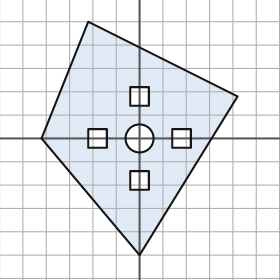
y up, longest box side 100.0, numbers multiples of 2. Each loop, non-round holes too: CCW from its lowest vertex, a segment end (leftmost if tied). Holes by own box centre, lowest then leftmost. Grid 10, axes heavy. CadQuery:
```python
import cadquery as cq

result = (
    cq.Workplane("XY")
    .moveTo(0.0, -50.0)
    .lineTo(42.0, 18.0)
    .lineTo(-22.0, 50.0)
    .lineTo(-42.0, 0.0)
    .close()
    .moveTo(-4.0, -22.0)
    .lineTo(4.0, -22.0)
    .lineTo(4.0, -14.0)
    .lineTo(-4.0, -14.0)
    .close()
    .moveTo(-22.0, -4.0)
    .lineTo(-14.0, -4.0)
    .lineTo(-14.0, 4.0)
    .lineTo(-22.0, 4.0)
    .close()
    .moveTo(0.0, 0.0)
    .circle(6.0)
    .moveTo(14.0, -4.0)
    .lineTo(22.0, -4.0)
    .lineTo(22.0, 4.0)
    .lineTo(14.0, 4.0)
    .close()
    .moveTo(-4.0, 14.0)
    .lineTo(4.0, 14.0)
    .lineTo(4.0, 22.0)
    .lineTo(-4.0, 22.0)
    .close()
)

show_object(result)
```